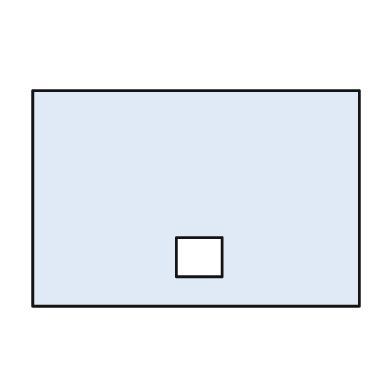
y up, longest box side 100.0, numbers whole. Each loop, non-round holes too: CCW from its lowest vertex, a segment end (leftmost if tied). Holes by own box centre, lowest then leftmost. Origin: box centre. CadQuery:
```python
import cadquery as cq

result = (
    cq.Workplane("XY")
    .moveTo(-50.0, -33.0)
    .lineTo(50.0, -33.0)
    .lineTo(50.0, 33.0)
    .lineTo(-50.0, 33.0)
    .close()
    .moveTo(-6.0, -24.0)
    .lineTo(8.0, -24.0)
    .lineTo(8.0, -12.0)
    .lineTo(-6.0, -12.0)
    .close()
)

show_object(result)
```